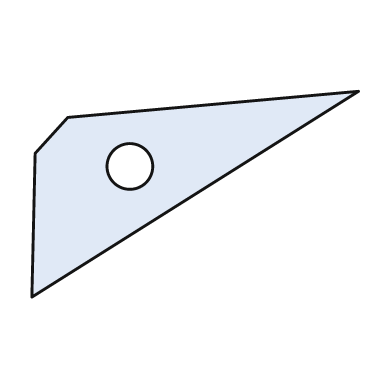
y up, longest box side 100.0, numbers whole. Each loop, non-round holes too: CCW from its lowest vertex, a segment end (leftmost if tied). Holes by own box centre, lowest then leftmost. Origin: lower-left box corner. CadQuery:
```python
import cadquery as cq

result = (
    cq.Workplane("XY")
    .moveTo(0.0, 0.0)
    .lineTo(100.0, 63.0)
    .lineTo(11.0, 55.0)
    .lineTo(1.0, 44.0)
    .close()
    .moveTo(30.0, 40.0)
    .circle(7.0)
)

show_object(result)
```